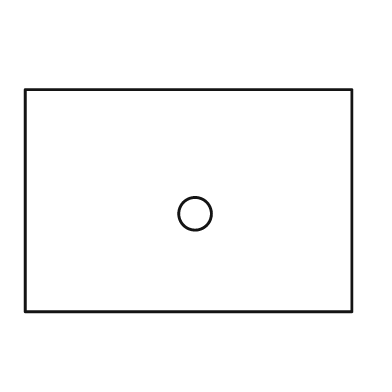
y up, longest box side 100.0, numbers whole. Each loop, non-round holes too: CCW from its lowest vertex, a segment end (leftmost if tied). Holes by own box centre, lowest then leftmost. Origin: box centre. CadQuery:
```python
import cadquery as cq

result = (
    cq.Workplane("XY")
    .moveTo(-50.0, -34.0)
    .lineTo(50.0, -34.0)
    .lineTo(50.0, 34.0)
    .lineTo(-50.0, 34.0)
    .close()
    .moveTo(2.0, -4.0)
    .circle(5.0)
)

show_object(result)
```